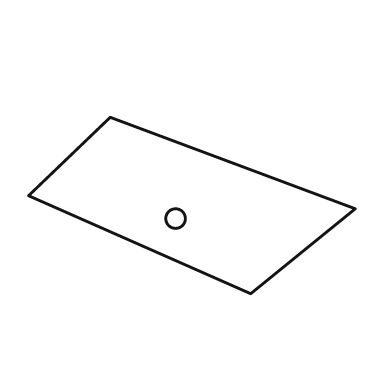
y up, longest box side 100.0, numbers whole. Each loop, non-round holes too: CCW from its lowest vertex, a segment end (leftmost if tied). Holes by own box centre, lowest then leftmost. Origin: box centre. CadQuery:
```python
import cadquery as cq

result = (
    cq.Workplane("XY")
    .moveTo(18.0, -27.0)
    .lineTo(50.0, -1.0)
    .lineTo(-25.0, 27.0)
    .lineTo(-50.0, 3.0)
    .close()
    .moveTo(-5.0, -4.0)
    .circle(3.0)
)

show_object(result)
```